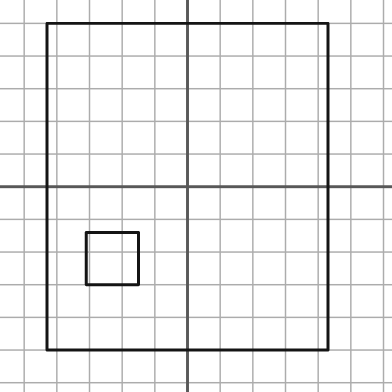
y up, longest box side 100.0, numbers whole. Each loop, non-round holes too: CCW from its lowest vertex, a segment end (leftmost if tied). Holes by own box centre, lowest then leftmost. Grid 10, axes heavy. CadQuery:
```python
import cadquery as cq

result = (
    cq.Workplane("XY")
    .moveTo(-43.0, -50.0)
    .lineTo(43.0, -50.0)
    .lineTo(43.0, 50.0)
    .lineTo(-43.0, 50.0)
    .close()
    .moveTo(-31.0, -30.0)
    .lineTo(-15.0, -30.0)
    .lineTo(-15.0, -14.0)
    .lineTo(-31.0, -14.0)
    .close()
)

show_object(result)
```